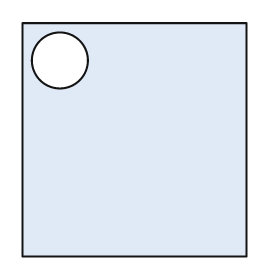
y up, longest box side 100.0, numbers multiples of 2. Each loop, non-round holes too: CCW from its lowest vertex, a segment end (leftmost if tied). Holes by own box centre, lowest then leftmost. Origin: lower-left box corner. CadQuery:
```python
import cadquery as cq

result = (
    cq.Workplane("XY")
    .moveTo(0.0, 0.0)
    .lineTo(96.0, 0.0)
    .lineTo(96.0, 100.0)
    .lineTo(0.0, 100.0)
    .close()
    .moveTo(16.0, 84.0)
    .circle(12.0)
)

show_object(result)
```